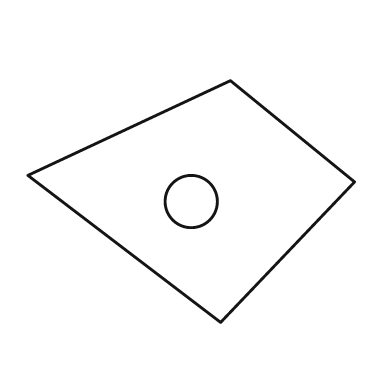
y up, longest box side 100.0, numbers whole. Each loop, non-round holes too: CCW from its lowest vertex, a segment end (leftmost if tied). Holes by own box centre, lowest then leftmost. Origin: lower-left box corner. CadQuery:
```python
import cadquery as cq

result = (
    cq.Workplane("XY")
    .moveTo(59.0, 0.0)
    .lineTo(100.0, 43.0)
    .lineTo(62.0, 74.0)
    .lineTo(0.0, 45.0)
    .close()
    .moveTo(50.0, 37.0)
    .circle(8.0)
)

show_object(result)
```